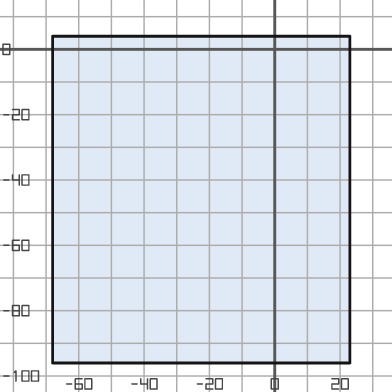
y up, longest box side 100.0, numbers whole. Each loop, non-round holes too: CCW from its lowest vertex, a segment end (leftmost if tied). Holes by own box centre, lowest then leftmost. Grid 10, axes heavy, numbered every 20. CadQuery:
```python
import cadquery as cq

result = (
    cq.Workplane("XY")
    .moveTo(-68.0, -96.0)
    .lineTo(23.0, -96.0)
    .lineTo(23.0, 4.0)
    .lineTo(-68.0, 4.0)
    .close()
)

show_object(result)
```